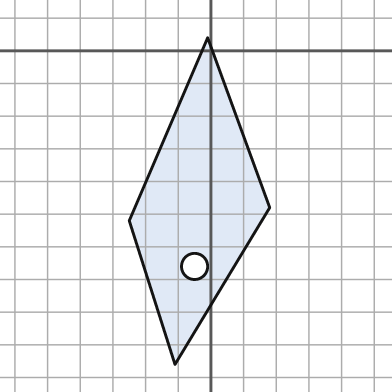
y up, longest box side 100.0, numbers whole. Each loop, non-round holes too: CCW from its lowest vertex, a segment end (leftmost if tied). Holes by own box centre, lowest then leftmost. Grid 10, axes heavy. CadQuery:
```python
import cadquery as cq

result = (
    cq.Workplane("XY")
    .moveTo(-11.0, -96.0)
    .lineTo(18.0, -48.0)
    .lineTo(-1.0, 4.0)
    .lineTo(-25.0, -52.0)
    .close()
    .moveTo(-5.0, -66.0)
    .circle(4.0)
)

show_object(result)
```